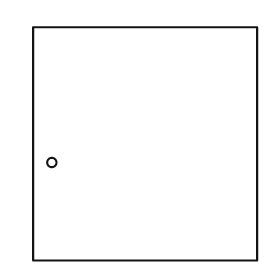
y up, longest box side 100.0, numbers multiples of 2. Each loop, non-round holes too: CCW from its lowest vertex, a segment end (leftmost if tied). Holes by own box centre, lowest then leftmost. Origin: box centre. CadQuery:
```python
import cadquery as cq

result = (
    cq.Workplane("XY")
    .moveTo(-48.0, -50.0)
    .lineTo(48.0, -50.0)
    .lineTo(48.0, 50.0)
    .lineTo(-48.0, 50.0)
    .close()
    .moveTo(-40.0, -8.0)
    .circle(2.0)
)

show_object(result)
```